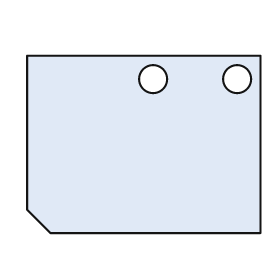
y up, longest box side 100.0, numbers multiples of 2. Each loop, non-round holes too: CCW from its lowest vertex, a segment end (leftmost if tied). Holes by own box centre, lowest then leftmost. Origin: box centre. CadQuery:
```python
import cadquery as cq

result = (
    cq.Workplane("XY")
    .moveTo(-40.0, -38.0)
    .lineTo(50.0, -38.0)
    .lineTo(50.0, 38.0)
    .lineTo(-50.0, 38.0)
    .lineTo(-50.0, -28.0)
    .close()
    .moveTo(4.0, 28.0)
    .circle(6.0)
    .moveTo(40.0, 28.0)
    .circle(6.0)
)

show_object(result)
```